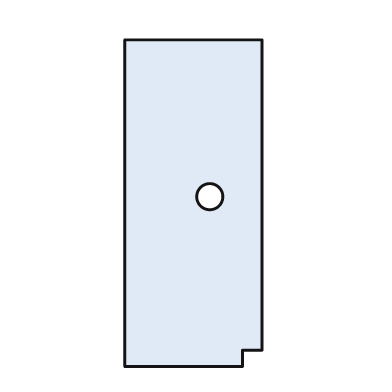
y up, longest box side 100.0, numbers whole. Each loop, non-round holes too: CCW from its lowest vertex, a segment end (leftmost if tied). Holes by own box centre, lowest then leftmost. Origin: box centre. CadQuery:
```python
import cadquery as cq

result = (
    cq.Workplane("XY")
    .moveTo(-21.0, -50.0)
    .lineTo(15.0, -50.0)
    .lineTo(15.0, -45.0)
    .lineTo(21.0, -45.0)
    .lineTo(21.0, 50.0)
    .lineTo(-21.0, 50.0)
    .close()
    .moveTo(5.0, 2.0)
    .circle(4.0)
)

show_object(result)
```